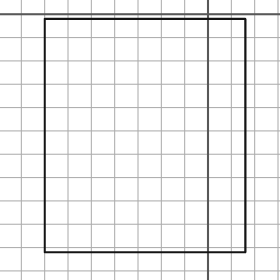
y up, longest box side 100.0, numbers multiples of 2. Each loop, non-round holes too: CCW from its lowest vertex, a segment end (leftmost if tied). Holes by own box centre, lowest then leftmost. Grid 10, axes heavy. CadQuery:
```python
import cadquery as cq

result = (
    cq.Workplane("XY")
    .moveTo(-70.0, -102.0)
    .lineTo(16.0, -102.0)
    .lineTo(16.0, -2.0)
    .lineTo(-70.0, -2.0)
    .close()
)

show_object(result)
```